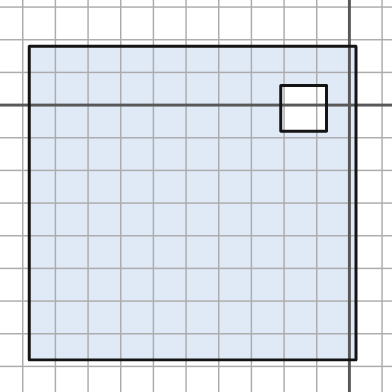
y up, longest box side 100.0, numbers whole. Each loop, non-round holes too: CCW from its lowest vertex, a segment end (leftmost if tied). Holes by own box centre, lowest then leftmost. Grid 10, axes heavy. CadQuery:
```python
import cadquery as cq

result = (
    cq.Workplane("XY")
    .moveTo(-98.0, -78.0)
    .lineTo(2.0, -78.0)
    .lineTo(2.0, 18.0)
    .lineTo(-98.0, 18.0)
    .close()
    .moveTo(-21.0, -8.0)
    .lineTo(-7.0, -8.0)
    .lineTo(-7.0, 6.0)
    .lineTo(-21.0, 6.0)
    .close()
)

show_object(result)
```